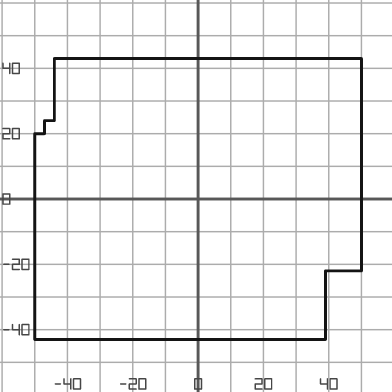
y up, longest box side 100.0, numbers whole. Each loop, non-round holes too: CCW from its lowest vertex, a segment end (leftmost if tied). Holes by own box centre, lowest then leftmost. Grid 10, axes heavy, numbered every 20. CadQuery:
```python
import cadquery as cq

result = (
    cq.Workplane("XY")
    .moveTo(-50.0, -43.0)
    .lineTo(39.0, -43.0)
    .lineTo(39.0, -22.0)
    .lineTo(50.0, -22.0)
    .lineTo(50.0, 43.0)
    .lineTo(-44.0, 43.0)
    .lineTo(-44.0, 24.0)
    .lineTo(-47.0, 24.0)
    .lineTo(-47.0, 20.0)
    .lineTo(-50.0, 20.0)
    .close()
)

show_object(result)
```